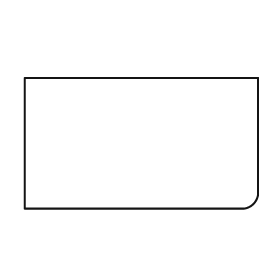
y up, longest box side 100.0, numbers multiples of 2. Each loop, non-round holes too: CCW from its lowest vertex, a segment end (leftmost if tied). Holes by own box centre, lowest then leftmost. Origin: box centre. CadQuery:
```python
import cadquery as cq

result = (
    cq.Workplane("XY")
    .moveTo(-50.0, -28.0)
    .lineTo(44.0, -28.0)
    .threePointArc((48.0, -26.0), (50.0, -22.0))
    .lineTo(50.0, 28.0)
    .lineTo(-50.0, 28.0)
    .close()
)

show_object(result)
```